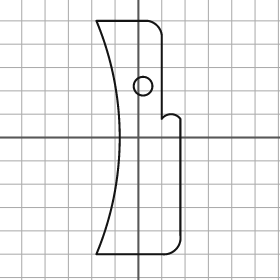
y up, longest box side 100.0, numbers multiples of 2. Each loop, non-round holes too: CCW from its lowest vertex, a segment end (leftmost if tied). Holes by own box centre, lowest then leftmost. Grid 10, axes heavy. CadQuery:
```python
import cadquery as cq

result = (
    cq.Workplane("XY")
    .moveTo(-18.0, -50.0)
    .lineTo(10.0, -50.0)
    .threePointArc((16.0, -48.0), (18.0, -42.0))
    .lineTo(18.0, 8.0)
    .threePointArc((14.0, 10.0), (10.0, 8.0))
    .lineTo(10.0, 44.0)
    .threePointArc((8.0, 48.0), (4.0, 50.0))
    .lineTo(-18.0, 50.0)
    .threePointArc((-8.0, 0.0), (-18.0, -50.0))
    .close()
    .moveTo(2.0, 22.0)
    .circle(4.0)
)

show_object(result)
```